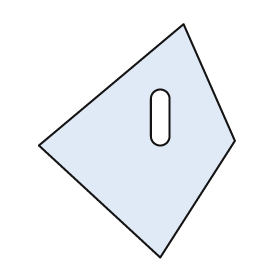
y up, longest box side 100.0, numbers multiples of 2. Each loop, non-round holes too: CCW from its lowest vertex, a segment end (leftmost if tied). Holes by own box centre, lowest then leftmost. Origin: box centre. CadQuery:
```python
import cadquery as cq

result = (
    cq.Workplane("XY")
    .moveTo(10.0, -50.0)
    .lineTo(42.0, 0.0)
    .lineTo(20.0, 50.0)
    .lineTo(-42.0, -2.0)
    .close()
    .moveTo(6.0, 2.0)
    .threePointArc((10.0, -2.0), (14.0, 2.0))
    .lineTo(14.0, 18.0)
    .threePointArc((10.0, 22.0), (6.0, 18.0))
    .close()
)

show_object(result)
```